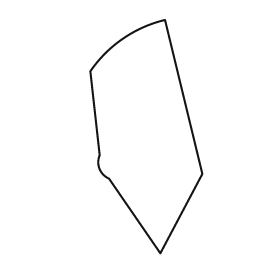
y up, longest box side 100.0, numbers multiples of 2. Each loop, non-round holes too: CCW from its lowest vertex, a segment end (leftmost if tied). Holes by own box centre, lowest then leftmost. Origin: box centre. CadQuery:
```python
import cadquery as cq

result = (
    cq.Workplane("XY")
    .moveTo(6.0, -50.0)
    .lineTo(24.0, -16.0)
    .lineTo(8.0, 50.0)
    .threePointArc((-10.0, 42.0), (-24.0, 28.0))
    .lineTo(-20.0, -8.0)
    .threePointArc((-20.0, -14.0), (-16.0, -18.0))
    .close()
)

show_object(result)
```